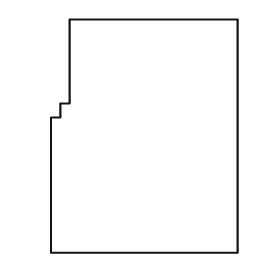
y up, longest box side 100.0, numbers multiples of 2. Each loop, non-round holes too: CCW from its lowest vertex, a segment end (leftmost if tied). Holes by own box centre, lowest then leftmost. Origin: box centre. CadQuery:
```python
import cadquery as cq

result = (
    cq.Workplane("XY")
    .moveTo(-40.0, -50.0)
    .lineTo(40.0, -50.0)
    .lineTo(40.0, 50.0)
    .lineTo(-32.0, 50.0)
    .lineTo(-32.0, 14.0)
    .lineTo(-36.0, 14.0)
    .lineTo(-36.0, 8.0)
    .lineTo(-40.0, 8.0)
    .close()
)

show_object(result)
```